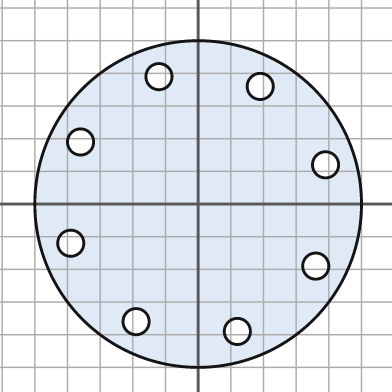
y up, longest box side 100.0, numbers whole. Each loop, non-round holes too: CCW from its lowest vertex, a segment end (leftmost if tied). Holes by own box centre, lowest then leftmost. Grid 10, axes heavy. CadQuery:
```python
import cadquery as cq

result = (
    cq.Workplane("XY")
    .moveTo(0.0, 0.0)
    .circle(50.0)
    .moveTo(12.0, -39.0)
    .circle(4.0)
    .moveTo(-19.0, -36.0)
    .circle(4.0)
    .moveTo(36.0, -19.0)
    .circle(4.0)
    .moveTo(-39.0, -12.0)
    .circle(4.0)
    .moveTo(39.0, 12.0)
    .circle(4.0)
    .moveTo(-36.0, 19.0)
    .circle(4.0)
    .moveTo(19.0, 36.0)
    .circle(4.0)
    .moveTo(-12.0, 39.0)
    .circle(4.0)
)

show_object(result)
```